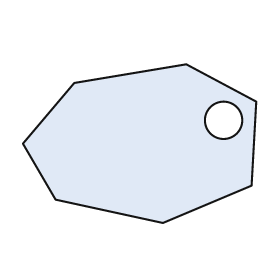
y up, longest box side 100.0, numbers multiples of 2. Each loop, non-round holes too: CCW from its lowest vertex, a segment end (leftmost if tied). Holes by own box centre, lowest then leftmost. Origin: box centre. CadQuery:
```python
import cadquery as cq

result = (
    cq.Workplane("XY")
    .moveTo(10.0, -34.0)
    .lineTo(48.0, -18.0)
    .lineTo(50.0, 18.0)
    .lineTo(20.0, 34.0)
    .lineTo(-28.0, 26.0)
    .lineTo(-50.0, 0.0)
    .lineTo(-36.0, -24.0)
    .close()
    .moveTo(36.0, 10.0)
    .circle(8.0)
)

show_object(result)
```